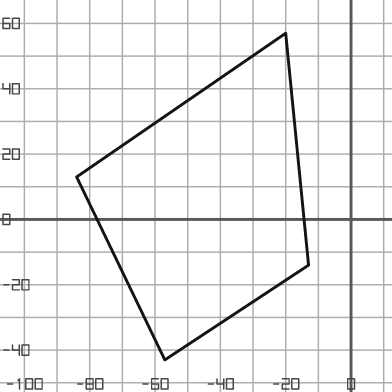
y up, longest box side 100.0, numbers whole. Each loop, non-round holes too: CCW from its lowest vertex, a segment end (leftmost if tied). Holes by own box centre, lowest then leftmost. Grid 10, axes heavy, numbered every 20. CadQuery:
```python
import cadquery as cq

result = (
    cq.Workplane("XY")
    .moveTo(-57.0, -43.0)
    .lineTo(-13.0, -14.0)
    .lineTo(-20.0, 57.0)
    .lineTo(-84.0, 13.0)
    .close()
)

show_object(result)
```